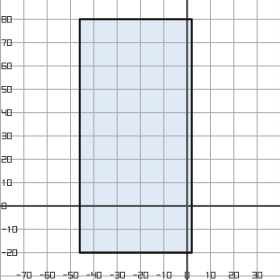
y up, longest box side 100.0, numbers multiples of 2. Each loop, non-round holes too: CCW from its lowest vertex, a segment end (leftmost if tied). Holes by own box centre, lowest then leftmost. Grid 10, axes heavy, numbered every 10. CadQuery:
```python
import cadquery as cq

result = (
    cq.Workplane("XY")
    .moveTo(-46.0, -20.0)
    .lineTo(2.0, -20.0)
    .lineTo(2.0, 80.0)
    .lineTo(-46.0, 80.0)
    .close()
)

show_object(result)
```